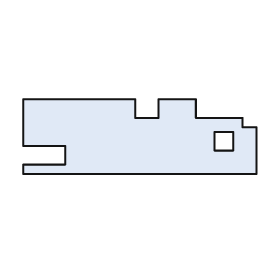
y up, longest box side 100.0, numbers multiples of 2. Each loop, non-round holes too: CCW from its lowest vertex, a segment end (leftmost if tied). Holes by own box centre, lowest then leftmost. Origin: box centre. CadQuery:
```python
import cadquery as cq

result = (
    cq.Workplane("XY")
    .moveTo(-50.0, -16.0)
    .lineTo(50.0, -16.0)
    .lineTo(50.0, 4.0)
    .lineTo(44.0, 4.0)
    .lineTo(44.0, 8.0)
    .lineTo(24.0, 8.0)
    .lineTo(24.0, 16.0)
    .lineTo(8.0, 16.0)
    .lineTo(8.0, 8.0)
    .lineTo(-2.0, 8.0)
    .lineTo(-2.0, 16.0)
    .lineTo(-50.0, 16.0)
    .lineTo(-50.0, -4.0)
    .lineTo(-32.0, -4.0)
    .lineTo(-32.0, -12.0)
    .lineTo(-50.0, -12.0)
    .close()
    .moveTo(32.0, -6.0)
    .lineTo(40.0, -6.0)
    .lineTo(40.0, 2.0)
    .lineTo(32.0, 2.0)
    .close()
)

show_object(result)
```